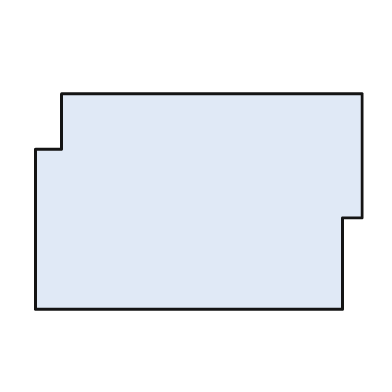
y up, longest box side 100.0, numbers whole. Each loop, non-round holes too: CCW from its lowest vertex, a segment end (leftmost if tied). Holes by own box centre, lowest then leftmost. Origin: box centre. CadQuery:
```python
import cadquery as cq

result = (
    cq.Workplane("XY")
    .moveTo(-50.0, -33.0)
    .lineTo(44.0, -33.0)
    .lineTo(44.0, -5.0)
    .lineTo(50.0, -5.0)
    .lineTo(50.0, 33.0)
    .lineTo(-42.0, 33.0)
    .lineTo(-42.0, 16.0)
    .lineTo(-50.0, 16.0)
    .close()
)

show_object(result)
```